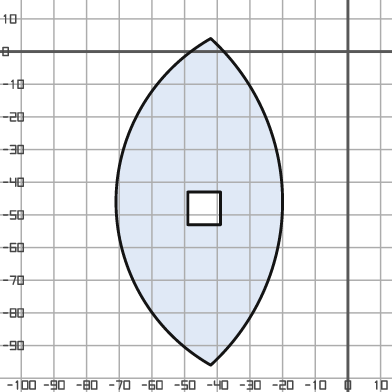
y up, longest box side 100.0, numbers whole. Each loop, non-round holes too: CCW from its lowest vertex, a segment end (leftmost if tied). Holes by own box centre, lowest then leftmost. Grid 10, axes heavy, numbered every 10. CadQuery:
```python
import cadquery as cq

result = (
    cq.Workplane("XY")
    .moveTo(-42.0, -96.0)
    .threePointArc((-20.0, -46.0), (-42.0, 4.0))
    .threePointArc((-71.0, -46.0), (-42.0, -96.0))
    .close()
    .moveTo(-49.0, -53.0)
    .lineTo(-39.0, -53.0)
    .lineTo(-39.0, -43.0)
    .lineTo(-49.0, -43.0)
    .close()
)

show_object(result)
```